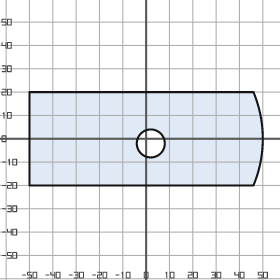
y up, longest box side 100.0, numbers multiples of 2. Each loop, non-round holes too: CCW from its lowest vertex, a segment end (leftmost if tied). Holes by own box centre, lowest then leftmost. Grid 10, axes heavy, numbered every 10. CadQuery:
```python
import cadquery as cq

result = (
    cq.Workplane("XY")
    .moveTo(-50.0, -20.0)
    .lineTo(46.0, -20.0)
    .threePointArc((50.0, 0.0), (46.0, 20.0))
    .lineTo(-50.0, 20.0)
    .close()
    .moveTo(2.0, -2.0)
    .circle(6.0)
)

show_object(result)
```